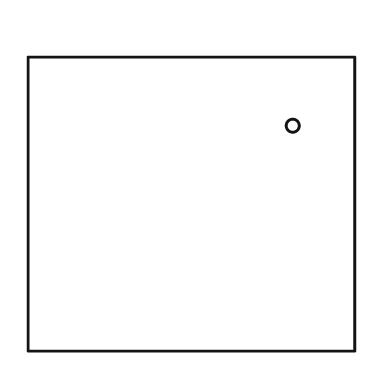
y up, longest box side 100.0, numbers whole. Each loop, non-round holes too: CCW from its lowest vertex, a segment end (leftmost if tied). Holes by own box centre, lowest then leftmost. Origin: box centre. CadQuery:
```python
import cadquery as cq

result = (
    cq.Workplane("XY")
    .moveTo(-50.0, -45.0)
    .lineTo(50.0, -45.0)
    .lineTo(50.0, 45.0)
    .lineTo(-50.0, 45.0)
    .close()
    .moveTo(31.0, 24.0)
    .circle(2.0)
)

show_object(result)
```